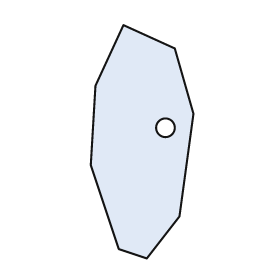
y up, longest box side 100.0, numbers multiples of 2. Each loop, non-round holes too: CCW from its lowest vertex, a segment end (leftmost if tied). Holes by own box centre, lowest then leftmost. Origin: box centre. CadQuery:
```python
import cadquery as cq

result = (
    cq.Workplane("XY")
    .moveTo(2.0, -50.0)
    .lineTo(16.0, -32.0)
    .lineTo(22.0, 12.0)
    .lineTo(14.0, 40.0)
    .lineTo(-8.0, 50.0)
    .lineTo(-20.0, 24.0)
    .lineTo(-22.0, -10.0)
    .lineTo(-10.0, -46.0)
    .close()
    .moveTo(10.0, 6.0)
    .circle(4.0)
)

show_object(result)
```